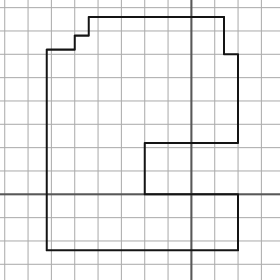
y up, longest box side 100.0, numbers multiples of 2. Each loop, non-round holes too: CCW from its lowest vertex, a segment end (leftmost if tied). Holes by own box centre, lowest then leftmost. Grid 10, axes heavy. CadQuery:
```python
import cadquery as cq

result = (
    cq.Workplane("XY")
    .moveTo(-62.0, -24.0)
    .lineTo(20.0, -24.0)
    .lineTo(20.0, 0.0)
    .lineTo(-20.0, 0.0)
    .lineTo(-20.0, 22.0)
    .lineTo(20.0, 22.0)
    .lineTo(20.0, 60.0)
    .lineTo(14.0, 60.0)
    .lineTo(14.0, 76.0)
    .lineTo(-44.0, 76.0)
    .lineTo(-44.0, 68.0)
    .lineTo(-50.0, 68.0)
    .lineTo(-50.0, 62.0)
    .lineTo(-62.0, 62.0)
    .close()
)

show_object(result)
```